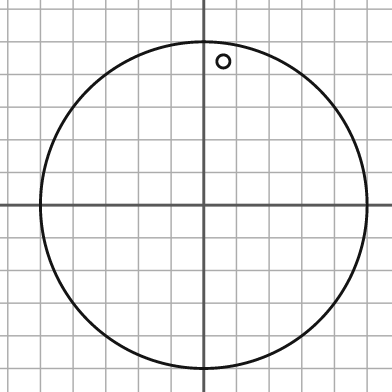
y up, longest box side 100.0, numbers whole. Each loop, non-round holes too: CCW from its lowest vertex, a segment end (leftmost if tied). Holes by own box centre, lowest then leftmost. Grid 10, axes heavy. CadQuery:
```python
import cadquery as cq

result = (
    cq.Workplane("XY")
    .moveTo(0.0, 0.0)
    .circle(50.0)
    .moveTo(6.0, 44.0)
    .circle(2.0)
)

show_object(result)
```